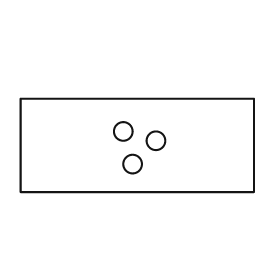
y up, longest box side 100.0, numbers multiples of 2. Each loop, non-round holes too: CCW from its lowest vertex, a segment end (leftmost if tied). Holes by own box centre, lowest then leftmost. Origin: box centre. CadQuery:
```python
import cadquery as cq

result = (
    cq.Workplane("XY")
    .moveTo(-50.0, -20.0)
    .lineTo(50.0, -20.0)
    .lineTo(50.0, 20.0)
    .lineTo(-50.0, 20.0)
    .close()
    .moveTo(-2.0, -8.0)
    .circle(4.0)
    .moveTo(8.0, 2.0)
    .circle(4.0)
    .moveTo(-6.0, 6.0)
    .circle(4.0)
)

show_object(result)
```